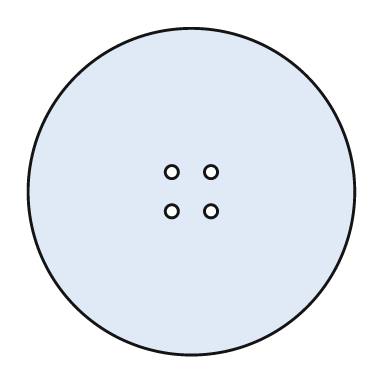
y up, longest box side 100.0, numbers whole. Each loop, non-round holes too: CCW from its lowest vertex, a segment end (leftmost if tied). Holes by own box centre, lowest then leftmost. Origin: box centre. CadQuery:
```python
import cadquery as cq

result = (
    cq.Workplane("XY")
    .moveTo(0.0, 0.0)
    .circle(50.0)
    .moveTo(-6.0, -6.0)
    .circle(2.0)
    .moveTo(6.0, -6.0)
    .circle(2.0)
    .moveTo(-6.0, 6.0)
    .circle(2.0)
    .moveTo(6.0, 6.0)
    .circle(2.0)
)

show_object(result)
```